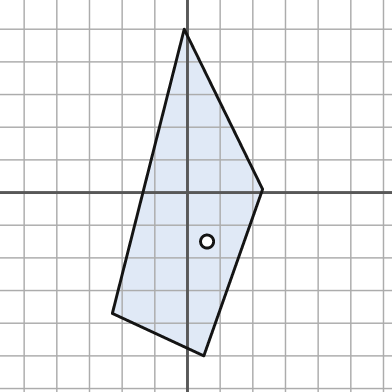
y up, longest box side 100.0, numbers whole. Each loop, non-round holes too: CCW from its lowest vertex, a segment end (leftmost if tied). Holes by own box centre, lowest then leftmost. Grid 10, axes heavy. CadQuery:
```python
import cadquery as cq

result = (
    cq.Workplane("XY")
    .moveTo(5.0, -50.0)
    .lineTo(23.0, 1.0)
    .lineTo(-1.0, 50.0)
    .lineTo(-23.0, -37.0)
    .close()
    .moveTo(6.0, -15.0)
    .circle(2.0)
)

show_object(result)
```